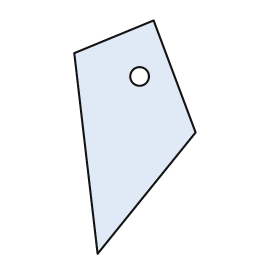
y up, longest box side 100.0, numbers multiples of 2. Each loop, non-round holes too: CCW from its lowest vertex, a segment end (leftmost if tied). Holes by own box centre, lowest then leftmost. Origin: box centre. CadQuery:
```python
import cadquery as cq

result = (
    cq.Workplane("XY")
    .moveTo(-16.0, -50.0)
    .lineTo(26.0, 2.0)
    .lineTo(8.0, 50.0)
    .lineTo(-26.0, 36.0)
    .close()
    .moveTo(2.0, 26.0)
    .circle(4.0)
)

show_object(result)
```